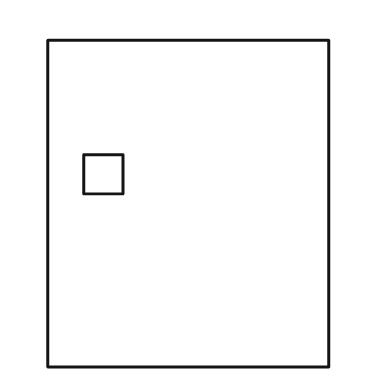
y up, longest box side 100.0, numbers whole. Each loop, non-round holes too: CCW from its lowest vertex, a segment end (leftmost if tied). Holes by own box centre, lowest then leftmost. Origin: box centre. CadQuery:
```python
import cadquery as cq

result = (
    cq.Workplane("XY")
    .moveTo(-43.0, -50.0)
    .lineTo(43.0, -50.0)
    .lineTo(43.0, 50.0)
    .lineTo(-43.0, 50.0)
    .close()
    .moveTo(-32.0, 3.0)
    .lineTo(-20.0, 3.0)
    .lineTo(-20.0, 15.0)
    .lineTo(-32.0, 15.0)
    .close()
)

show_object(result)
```